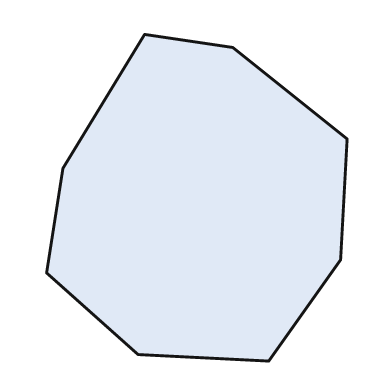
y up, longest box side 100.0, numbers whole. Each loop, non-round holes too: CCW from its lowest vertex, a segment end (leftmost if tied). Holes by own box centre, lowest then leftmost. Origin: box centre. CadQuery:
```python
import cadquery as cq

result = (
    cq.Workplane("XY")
    .moveTo(22.0, -50.0)
    .lineTo(44.0, -19.0)
    .lineTo(46.0, 18.0)
    .lineTo(11.0, 46.0)
    .lineTo(-16.0, 50.0)
    .lineTo(-41.0, 9.0)
    .lineTo(-46.0, -23.0)
    .lineTo(-18.0, -48.0)
    .close()
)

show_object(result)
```